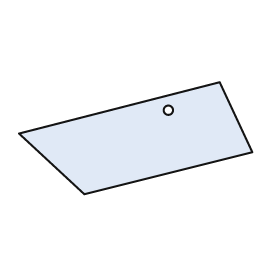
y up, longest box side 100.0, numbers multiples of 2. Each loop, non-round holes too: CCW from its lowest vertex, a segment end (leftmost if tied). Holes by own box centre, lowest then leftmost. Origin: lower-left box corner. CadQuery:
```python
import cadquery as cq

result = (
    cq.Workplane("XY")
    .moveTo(28.0, 0.0)
    .lineTo(100.0, 18.0)
    .lineTo(86.0, 48.0)
    .lineTo(0.0, 26.0)
    .close()
    .moveTo(64.0, 36.0)
    .circle(2.0)
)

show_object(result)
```